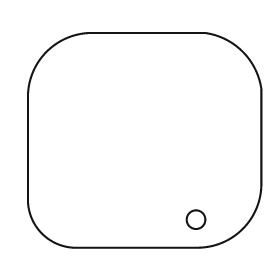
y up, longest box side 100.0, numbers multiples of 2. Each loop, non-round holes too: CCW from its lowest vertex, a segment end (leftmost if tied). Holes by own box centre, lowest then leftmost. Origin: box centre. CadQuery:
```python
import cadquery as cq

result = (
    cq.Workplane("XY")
    .moveTo(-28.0, -46.0)
    .lineTo(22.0, -46.0)
    .threePointArc((42.0, -38.0), (50.0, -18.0))
    .lineTo(50.0, 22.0)
    .threePointArc((42.0, 38.0), (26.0, 46.0))
    .lineTo(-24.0, 46.0)
    .threePointArc((-42.0, 38.0), (-50.0, 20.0))
    .lineTo(-50.0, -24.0)
    .threePointArc((-44.0, -40.0), (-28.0, -46.0))
    .close()
    .moveTo(22.0, -34.0)
    .circle(4.0)
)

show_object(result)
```